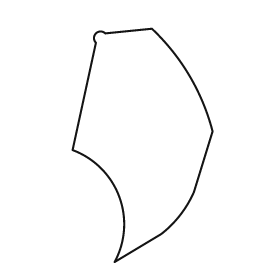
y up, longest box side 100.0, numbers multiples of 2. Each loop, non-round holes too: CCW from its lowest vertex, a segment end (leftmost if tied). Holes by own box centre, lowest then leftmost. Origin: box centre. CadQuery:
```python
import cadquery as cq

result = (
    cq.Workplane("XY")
    .moveTo(-12.0, -50.0)
    .lineTo(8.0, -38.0)
    .threePointArc((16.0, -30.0), (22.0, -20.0))
    .lineTo(30.0, 6.0)
    .threePointArc((20.0, 30.0), (4.0, 50.0))
    .lineTo(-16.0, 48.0)
    .threePointArc((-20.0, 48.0), (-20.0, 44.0))
    .lineTo(-30.0, -2.0)
    .threePointArc((-10.0, -22.0), (-12.0, -50.0))
    .close()
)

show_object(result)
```